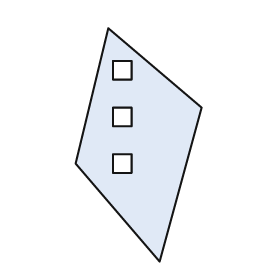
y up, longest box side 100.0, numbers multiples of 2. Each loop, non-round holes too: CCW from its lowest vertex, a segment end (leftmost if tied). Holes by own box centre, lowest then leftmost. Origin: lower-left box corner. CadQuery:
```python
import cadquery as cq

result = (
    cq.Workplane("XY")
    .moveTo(36.0, 0.0)
    .lineTo(54.0, 66.0)
    .lineTo(14.0, 100.0)
    .lineTo(0.0, 42.0)
    .close()
    .moveTo(16.0, 38.0)
    .lineTo(24.0, 38.0)
    .lineTo(24.0, 46.0)
    .lineTo(16.0, 46.0)
    .close()
    .moveTo(16.0, 58.0)
    .lineTo(24.0, 58.0)
    .lineTo(24.0, 66.0)
    .lineTo(16.0, 66.0)
    .close()
    .moveTo(16.0, 78.0)
    .lineTo(24.0, 78.0)
    .lineTo(24.0, 86.0)
    .lineTo(16.0, 86.0)
    .close()
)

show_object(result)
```